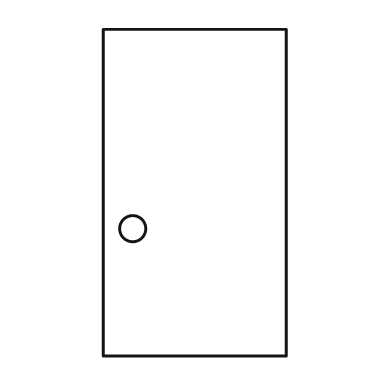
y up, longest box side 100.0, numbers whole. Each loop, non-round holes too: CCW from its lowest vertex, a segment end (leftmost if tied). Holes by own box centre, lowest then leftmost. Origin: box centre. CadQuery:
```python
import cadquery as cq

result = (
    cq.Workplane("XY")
    .moveTo(-28.0, -50.0)
    .lineTo(28.0, -50.0)
    .lineTo(28.0, 50.0)
    .lineTo(-28.0, 50.0)
    .close()
    .moveTo(-19.0, -11.0)
    .circle(4.0)
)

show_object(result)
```